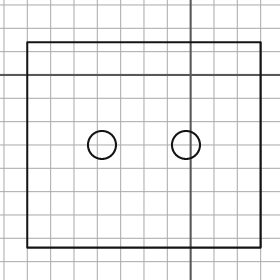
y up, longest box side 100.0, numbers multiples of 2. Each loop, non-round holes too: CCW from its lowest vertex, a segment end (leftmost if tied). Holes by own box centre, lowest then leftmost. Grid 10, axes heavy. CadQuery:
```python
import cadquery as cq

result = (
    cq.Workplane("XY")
    .moveTo(-70.0, -74.0)
    .lineTo(30.0, -74.0)
    .lineTo(30.0, 14.0)
    .lineTo(-70.0, 14.0)
    .close()
    .moveTo(-38.0, -30.0)
    .circle(6.0)
    .moveTo(-2.0, -30.0)
    .circle(6.0)
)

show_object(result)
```